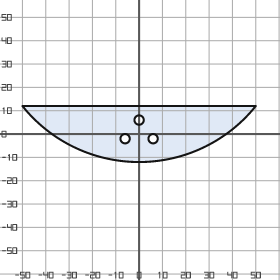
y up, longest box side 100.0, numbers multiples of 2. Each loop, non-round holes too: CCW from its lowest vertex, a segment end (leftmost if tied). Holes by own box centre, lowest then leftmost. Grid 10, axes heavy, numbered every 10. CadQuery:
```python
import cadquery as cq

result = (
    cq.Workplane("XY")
    .moveTo(-50.0, 12.0)
    .threePointArc((0.0, -12.0), (50.0, 12.0))
    .close()
    .moveTo(-6.0, -2.0)
    .circle(2.0)
    .moveTo(6.0, -2.0)
    .circle(2.0)
    .moveTo(0.0, 6.0)
    .circle(2.0)
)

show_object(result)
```